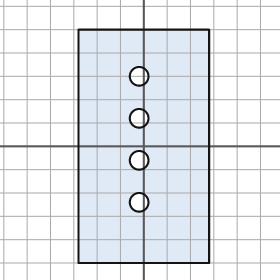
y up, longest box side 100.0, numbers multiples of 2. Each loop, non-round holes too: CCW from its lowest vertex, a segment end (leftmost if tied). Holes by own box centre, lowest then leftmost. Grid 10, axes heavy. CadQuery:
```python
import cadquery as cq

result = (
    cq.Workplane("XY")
    .moveTo(-28.0, -50.0)
    .lineTo(28.0, -50.0)
    .lineTo(28.0, 50.0)
    .lineTo(-28.0, 50.0)
    .close()
    .moveTo(-2.0, -24.0)
    .circle(4.0)
    .moveTo(-2.0, -6.0)
    .circle(4.0)
    .moveTo(-2.0, 12.0)
    .circle(4.0)
    .moveTo(-2.0, 30.0)
    .circle(4.0)
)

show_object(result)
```